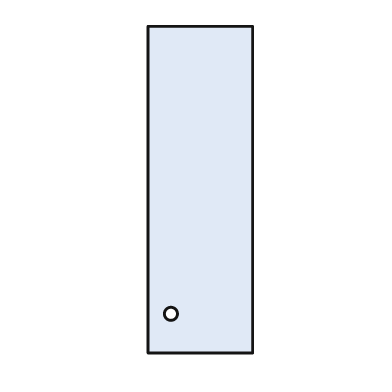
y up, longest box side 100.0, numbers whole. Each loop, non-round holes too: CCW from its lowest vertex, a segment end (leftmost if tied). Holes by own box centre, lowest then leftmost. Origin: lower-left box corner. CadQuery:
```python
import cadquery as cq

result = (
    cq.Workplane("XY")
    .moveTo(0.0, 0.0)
    .lineTo(32.0, 0.0)
    .lineTo(32.0, 100.0)
    .lineTo(0.0, 100.0)
    .close()
    .moveTo(7.0, 12.0)
    .circle(2.0)
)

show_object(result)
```